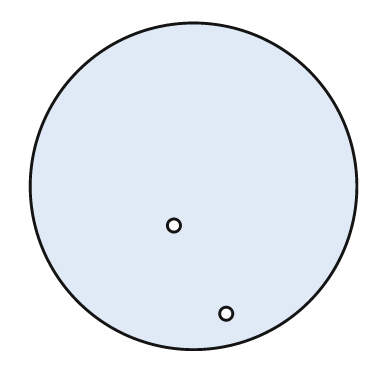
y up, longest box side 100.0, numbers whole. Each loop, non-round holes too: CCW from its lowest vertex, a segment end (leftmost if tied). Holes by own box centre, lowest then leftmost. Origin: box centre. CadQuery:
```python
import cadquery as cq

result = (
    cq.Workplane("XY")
    .moveTo(0.0, 0.0)
    .circle(50.0)
    .moveTo(10.0, -39.0)
    .circle(2.0)
    .moveTo(-6.0, -12.0)
    .circle(2.0)
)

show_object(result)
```